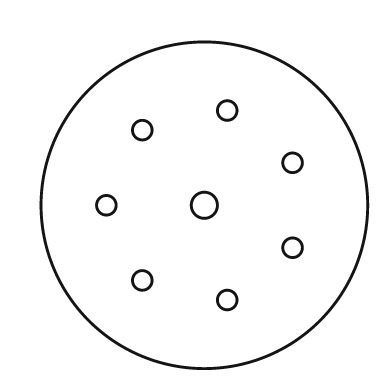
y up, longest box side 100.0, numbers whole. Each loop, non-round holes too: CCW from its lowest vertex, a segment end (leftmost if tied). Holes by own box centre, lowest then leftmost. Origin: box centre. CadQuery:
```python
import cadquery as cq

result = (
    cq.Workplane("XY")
    .moveTo(0.0, 0.0)
    .circle(50.0)
    .moveTo(7.0, -29.0)
    .circle(3.0)
    .moveTo(-19.0, -23.0)
    .circle(3.0)
    .moveTo(27.0, -13.0)
    .circle(3.0)
    .moveTo(-30.0, 0.0)
    .circle(3.0)
    .moveTo(0.0, 0.0)
    .circle(4.0)
    .moveTo(27.0, 13.0)
    .circle(3.0)
    .moveTo(-19.0, 23.0)
    .circle(3.0)
    .moveTo(7.0, 29.0)
    .circle(3.0)
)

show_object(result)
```